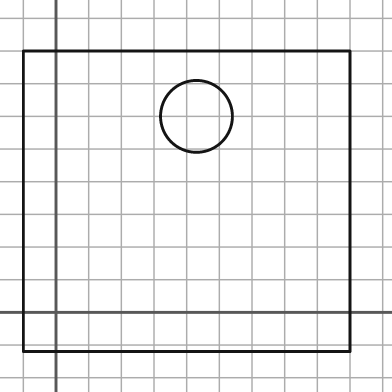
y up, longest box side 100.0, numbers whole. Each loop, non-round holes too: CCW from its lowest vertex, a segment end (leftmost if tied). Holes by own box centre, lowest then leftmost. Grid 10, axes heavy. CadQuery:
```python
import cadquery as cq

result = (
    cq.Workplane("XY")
    .moveTo(-10.0, -12.0)
    .lineTo(90.0, -12.0)
    .lineTo(90.0, 80.0)
    .lineTo(-10.0, 80.0)
    .close()
    .moveTo(43.0, 60.0)
    .circle(11.0)
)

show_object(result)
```